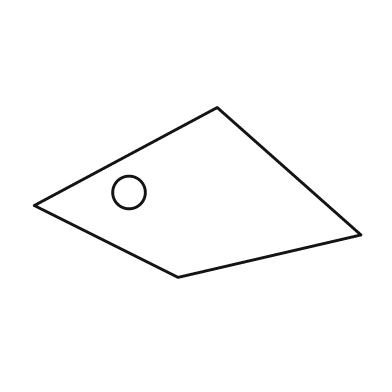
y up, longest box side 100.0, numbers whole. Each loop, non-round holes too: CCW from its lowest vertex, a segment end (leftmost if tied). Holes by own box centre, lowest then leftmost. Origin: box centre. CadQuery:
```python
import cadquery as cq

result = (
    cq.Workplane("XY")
    .moveTo(-6.0, -26.0)
    .lineTo(50.0, -13.0)
    .lineTo(6.0, 26.0)
    .lineTo(-50.0, -4.0)
    .close()
    .moveTo(-21.0, 0.0)
    .circle(5.0)
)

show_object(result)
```